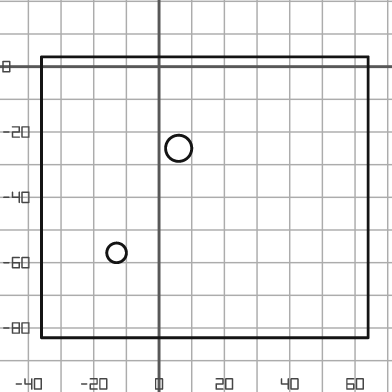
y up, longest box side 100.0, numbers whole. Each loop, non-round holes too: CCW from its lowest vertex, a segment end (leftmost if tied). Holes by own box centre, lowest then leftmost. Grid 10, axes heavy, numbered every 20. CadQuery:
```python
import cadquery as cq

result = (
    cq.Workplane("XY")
    .moveTo(-36.0, -83.0)
    .lineTo(64.0, -83.0)
    .lineTo(64.0, 3.0)
    .lineTo(-36.0, 3.0)
    .close()
    .moveTo(-13.0, -57.0)
    .circle(3.0)
    .moveTo(6.0, -25.0)
    .circle(4.0)
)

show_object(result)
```